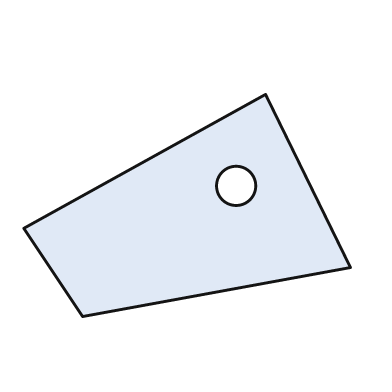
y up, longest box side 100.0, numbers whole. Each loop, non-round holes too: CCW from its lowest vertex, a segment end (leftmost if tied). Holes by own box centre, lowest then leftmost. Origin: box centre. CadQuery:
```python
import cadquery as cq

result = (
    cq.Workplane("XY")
    .moveTo(-32.0, -34.0)
    .lineTo(50.0, -19.0)
    .lineTo(24.0, 34.0)
    .lineTo(-50.0, -7.0)
    .close()
    .moveTo(15.0, 6.0)
    .circle(6.0)
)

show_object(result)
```